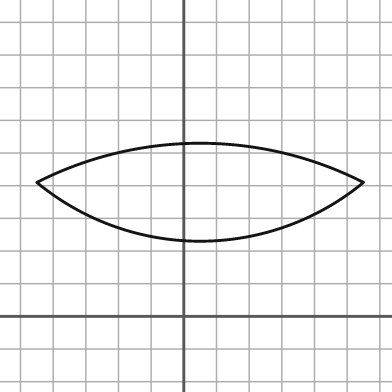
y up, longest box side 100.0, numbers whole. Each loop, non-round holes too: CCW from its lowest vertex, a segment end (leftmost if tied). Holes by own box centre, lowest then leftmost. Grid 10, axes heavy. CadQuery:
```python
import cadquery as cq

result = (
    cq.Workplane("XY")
    .moveTo(-45.0, 41.0)
    .threePointArc((5.0, 23.0), (55.0, 41.0))
    .threePointArc((5.0, 53.0), (-45.0, 41.0))
    .close()
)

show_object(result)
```